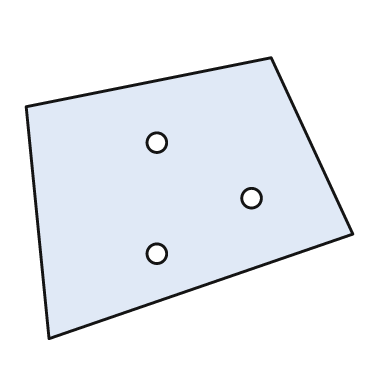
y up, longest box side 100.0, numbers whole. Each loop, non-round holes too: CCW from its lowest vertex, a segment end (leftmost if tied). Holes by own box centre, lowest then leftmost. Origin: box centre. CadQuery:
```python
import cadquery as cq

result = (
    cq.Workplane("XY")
    .moveTo(-43.0, -43.0)
    .lineTo(50.0, -11.0)
    .lineTo(25.0, 43.0)
    .lineTo(-50.0, 28.0)
    .close()
    .moveTo(-10.0, -17.0)
    .circle(3.0)
    .moveTo(19.0, 0.0)
    .circle(3.0)
    .moveTo(-10.0, 17.0)
    .circle(3.0)
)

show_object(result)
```